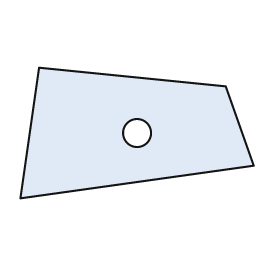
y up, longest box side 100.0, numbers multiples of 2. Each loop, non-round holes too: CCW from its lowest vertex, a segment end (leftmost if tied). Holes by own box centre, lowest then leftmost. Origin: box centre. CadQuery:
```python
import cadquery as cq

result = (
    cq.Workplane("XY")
    .moveTo(-50.0, -28.0)
    .lineTo(50.0, -14.0)
    .lineTo(38.0, 20.0)
    .lineTo(-42.0, 28.0)
    .close()
    .moveTo(0.0, 0.0)
    .circle(6.0)
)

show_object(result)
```